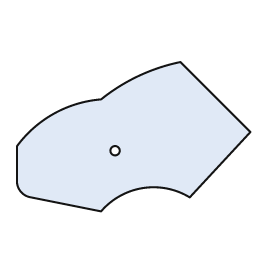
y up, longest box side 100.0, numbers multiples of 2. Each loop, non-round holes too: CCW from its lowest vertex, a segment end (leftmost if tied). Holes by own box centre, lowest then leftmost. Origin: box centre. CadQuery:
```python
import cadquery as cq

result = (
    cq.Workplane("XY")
    .moveTo(-14.0, -32.0)
    .threePointArc((4.0, -22.0), (24.0, -26.0))
    .lineTo(50.0, 2.0)
    .lineTo(20.0, 32.0)
    .threePointArc((2.0, 26.0), (-14.0, 16.0))
    .threePointArc((-34.0, 10.0), (-50.0, -4.0))
    .lineTo(-50.0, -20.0)
    .threePointArc((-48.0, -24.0), (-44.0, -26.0))
    .close()
    .moveTo(-8.0, -6.0)
    .circle(2.0)
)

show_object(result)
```